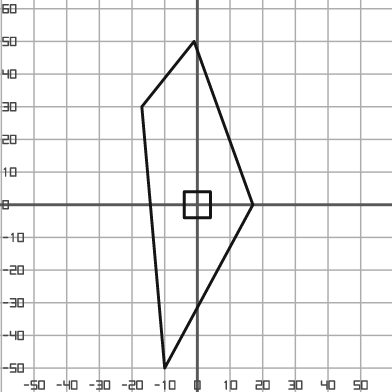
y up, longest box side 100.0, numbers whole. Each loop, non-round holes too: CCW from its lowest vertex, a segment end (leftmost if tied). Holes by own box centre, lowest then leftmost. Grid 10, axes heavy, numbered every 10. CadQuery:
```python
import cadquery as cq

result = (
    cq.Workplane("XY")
    .moveTo(-10.0, -50.0)
    .lineTo(17.0, 0.0)
    .lineTo(-1.0, 50.0)
    .lineTo(-17.0, 30.0)
    .close()
    .moveTo(-4.0, -4.0)
    .lineTo(4.0, -4.0)
    .lineTo(4.0, 4.0)
    .lineTo(-4.0, 4.0)
    .close()
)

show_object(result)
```